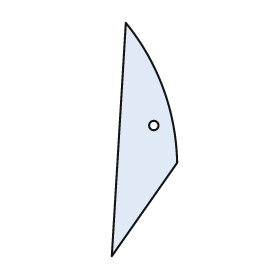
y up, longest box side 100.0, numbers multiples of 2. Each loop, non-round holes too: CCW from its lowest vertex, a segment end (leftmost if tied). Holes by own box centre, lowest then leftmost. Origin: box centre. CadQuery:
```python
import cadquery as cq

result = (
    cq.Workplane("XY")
    .moveTo(-14.0, -50.0)
    .lineTo(14.0, -10.0)
    .threePointArc((8.0, 22.0), (-8.0, 50.0))
    .close()
    .moveTo(4.0, 6.0)
    .circle(2.0)
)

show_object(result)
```